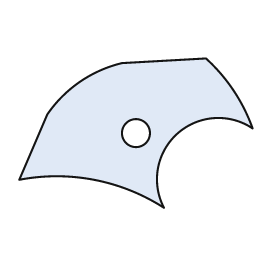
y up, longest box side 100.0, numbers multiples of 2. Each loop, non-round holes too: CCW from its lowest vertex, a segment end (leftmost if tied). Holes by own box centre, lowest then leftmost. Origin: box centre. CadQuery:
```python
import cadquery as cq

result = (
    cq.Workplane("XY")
    .moveTo(12.0, -32.0)
    .threePointArc((18.0, 0.0), (50.0, 2.0))
    .threePointArc((42.0, 18.0), (30.0, 32.0))
    .lineTo(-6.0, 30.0)
    .threePointArc((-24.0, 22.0), (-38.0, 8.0))
    .lineTo(-50.0, -20.0)
    .threePointArc((-18.0, -20.0), (12.0, -32.0))
    .close()
    .moveTo(0.0, 0.0)
    .circle(6.0)
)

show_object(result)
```